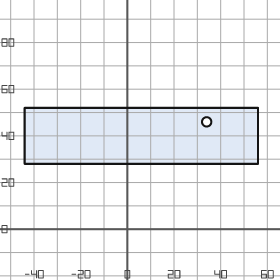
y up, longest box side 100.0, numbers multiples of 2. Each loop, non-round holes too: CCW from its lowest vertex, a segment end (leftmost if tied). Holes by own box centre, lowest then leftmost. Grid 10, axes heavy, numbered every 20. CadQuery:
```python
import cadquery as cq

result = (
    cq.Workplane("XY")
    .moveTo(-44.0, 28.0)
    .lineTo(56.0, 28.0)
    .lineTo(56.0, 52.0)
    .lineTo(-44.0, 52.0)
    .close()
    .moveTo(34.0, 46.0)
    .circle(2.0)
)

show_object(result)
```